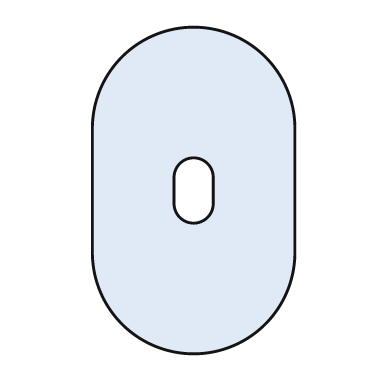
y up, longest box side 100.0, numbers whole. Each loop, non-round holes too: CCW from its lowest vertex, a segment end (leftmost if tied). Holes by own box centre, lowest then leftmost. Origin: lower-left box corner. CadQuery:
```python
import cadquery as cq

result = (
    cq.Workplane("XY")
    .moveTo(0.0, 31.0)
    .threePointArc((31.0, 0.0), (62.0, 31.0))
    .lineTo(62.0, 69.0)
    .threePointArc((31.0, 100.0), (0.0, 69.0))
    .close()
    .moveTo(25.0, 46.0)
    .threePointArc((31.0, 40.0), (37.0, 46.0))
    .lineTo(37.0, 54.0)
    .threePointArc((31.0, 60.0), (25.0, 54.0))
    .close()
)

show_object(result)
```